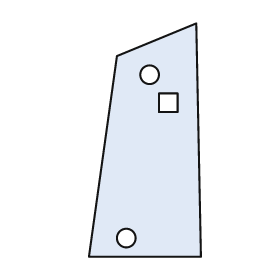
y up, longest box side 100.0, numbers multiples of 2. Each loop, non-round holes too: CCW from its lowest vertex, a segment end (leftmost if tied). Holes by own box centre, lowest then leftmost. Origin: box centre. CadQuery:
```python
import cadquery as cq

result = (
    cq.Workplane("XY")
    .moveTo(-24.0, -50.0)
    .lineTo(24.0, -50.0)
    .lineTo(22.0, 50.0)
    .lineTo(-12.0, 36.0)
    .close()
    .moveTo(-8.0, -42.0)
    .circle(4.0)
    .moveTo(6.0, 12.0)
    .lineTo(14.0, 12.0)
    .lineTo(14.0, 20.0)
    .lineTo(6.0, 20.0)
    .close()
    .moveTo(2.0, 28.0)
    .circle(4.0)
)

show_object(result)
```